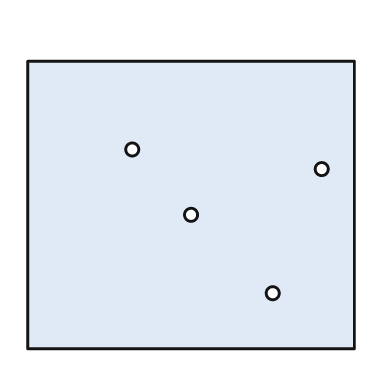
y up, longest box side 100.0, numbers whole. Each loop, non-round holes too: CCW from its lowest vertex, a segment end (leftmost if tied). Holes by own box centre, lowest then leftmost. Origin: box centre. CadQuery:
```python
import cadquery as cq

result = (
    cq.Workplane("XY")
    .moveTo(-50.0, -44.0)
    .lineTo(50.0, -44.0)
    .lineTo(50.0, 44.0)
    .lineTo(-50.0, 44.0)
    .close()
    .moveTo(25.0, -27.0)
    .circle(2.0)
    .moveTo(0.0, -3.0)
    .circle(2.0)
    .moveTo(40.0, 11.0)
    .circle(2.0)
    .moveTo(-18.0, 17.0)
    .circle(2.0)
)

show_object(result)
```